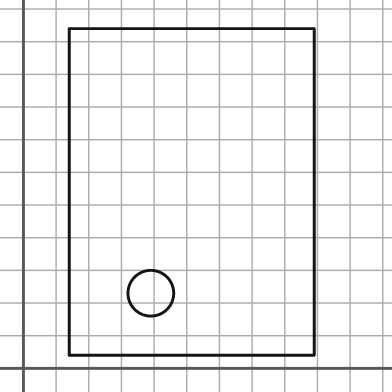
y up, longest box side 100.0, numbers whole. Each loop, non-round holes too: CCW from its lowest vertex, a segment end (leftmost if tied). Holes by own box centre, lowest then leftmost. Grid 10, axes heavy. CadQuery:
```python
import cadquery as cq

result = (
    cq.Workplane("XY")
    .moveTo(14.0, 4.0)
    .lineTo(89.0, 4.0)
    .lineTo(89.0, 104.0)
    .lineTo(14.0, 104.0)
    .close()
    .moveTo(39.0, 23.0)
    .circle(7.0)
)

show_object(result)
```